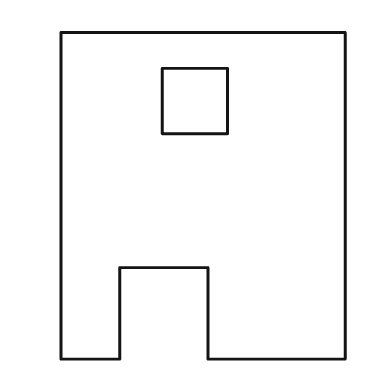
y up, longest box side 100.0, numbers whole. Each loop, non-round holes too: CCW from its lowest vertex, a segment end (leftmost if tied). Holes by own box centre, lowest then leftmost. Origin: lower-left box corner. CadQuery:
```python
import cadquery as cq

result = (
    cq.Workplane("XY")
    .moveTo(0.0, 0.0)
    .lineTo(18.0, 0.0)
    .lineTo(18.0, 28.0)
    .lineTo(45.0, 28.0)
    .lineTo(45.0, 0.0)
    .lineTo(87.0, 0.0)
    .lineTo(87.0, 100.0)
    .lineTo(0.0, 100.0)
    .close()
    .moveTo(31.0, 69.0)
    .lineTo(51.0, 69.0)
    .lineTo(51.0, 89.0)
    .lineTo(31.0, 89.0)
    .close()
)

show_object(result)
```